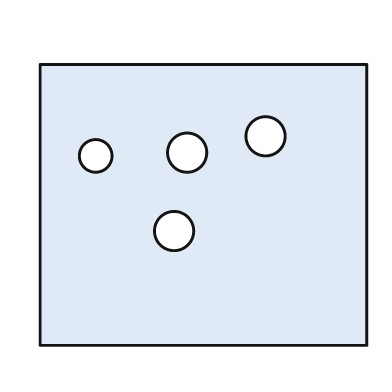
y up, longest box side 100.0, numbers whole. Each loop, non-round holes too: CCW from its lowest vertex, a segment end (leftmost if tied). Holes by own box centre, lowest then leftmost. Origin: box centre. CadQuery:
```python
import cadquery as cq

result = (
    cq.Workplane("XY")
    .moveTo(-50.0, -43.0)
    .lineTo(50.0, -43.0)
    .lineTo(50.0, 43.0)
    .lineTo(-50.0, 43.0)
    .close()
    .moveTo(-9.0, -8.0)
    .circle(6.0)
    .moveTo(-33.0, 15.0)
    .circle(5.0)
    .moveTo(-5.0, 16.0)
    .circle(6.0)
    .moveTo(19.0, 21.0)
    .circle(6.0)
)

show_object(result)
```